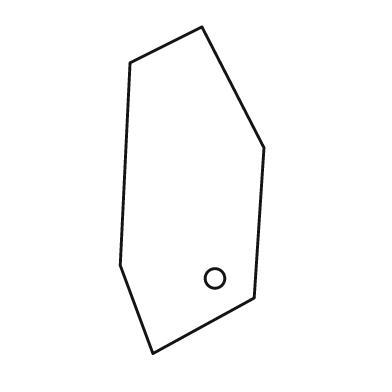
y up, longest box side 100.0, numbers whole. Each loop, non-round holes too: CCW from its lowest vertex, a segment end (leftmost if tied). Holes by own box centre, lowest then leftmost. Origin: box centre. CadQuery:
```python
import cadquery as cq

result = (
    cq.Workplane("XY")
    .moveTo(-12.0, -50.0)
    .lineTo(19.0, -33.0)
    .lineTo(22.0, 13.0)
    .lineTo(3.0, 50.0)
    .lineTo(-19.0, 39.0)
    .lineTo(-22.0, -23.0)
    .close()
    .moveTo(7.0, -27.0)
    .circle(3.0)
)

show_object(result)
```